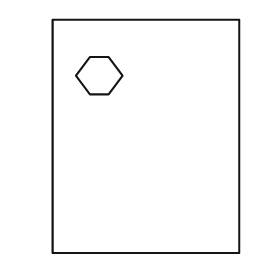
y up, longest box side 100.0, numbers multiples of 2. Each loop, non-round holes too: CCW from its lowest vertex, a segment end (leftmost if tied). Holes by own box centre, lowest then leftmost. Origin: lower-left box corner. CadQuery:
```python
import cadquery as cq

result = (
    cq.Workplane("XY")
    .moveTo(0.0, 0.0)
    .lineTo(80.0, 0.0)
    .lineTo(80.0, 100.0)
    .lineTo(0.0, 100.0)
    .close()
    .moveTo(16.0, 68.0)
    .lineTo(24.0, 68.0)
    .lineTo(30.0, 76.0)
    .lineTo(24.0, 84.0)
    .lineTo(16.0, 84.0)
    .lineTo(10.0, 76.0)
    .close()
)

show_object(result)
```